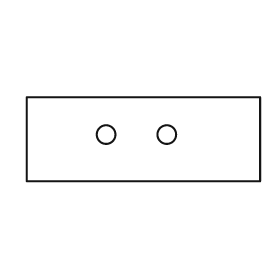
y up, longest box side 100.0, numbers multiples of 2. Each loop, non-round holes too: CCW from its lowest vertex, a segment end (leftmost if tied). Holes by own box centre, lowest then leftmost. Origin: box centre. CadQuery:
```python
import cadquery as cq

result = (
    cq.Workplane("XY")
    .moveTo(-50.0, -18.0)
    .lineTo(50.0, -18.0)
    .lineTo(50.0, 18.0)
    .lineTo(-50.0, 18.0)
    .close()
    .moveTo(-16.0, 2.0)
    .circle(4.0)
    .moveTo(10.0, 2.0)
    .circle(4.0)
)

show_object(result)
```